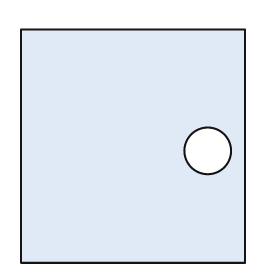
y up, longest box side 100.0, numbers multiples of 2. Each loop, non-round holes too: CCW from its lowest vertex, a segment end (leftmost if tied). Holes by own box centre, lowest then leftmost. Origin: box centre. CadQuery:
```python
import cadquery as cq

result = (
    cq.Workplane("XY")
    .moveTo(-48.0, -50.0)
    .lineTo(48.0, -50.0)
    .lineTo(48.0, 50.0)
    .lineTo(-48.0, 50.0)
    .close()
    .moveTo(32.0, -2.0)
    .circle(10.0)
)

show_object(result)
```